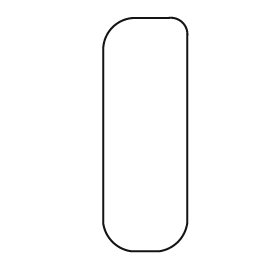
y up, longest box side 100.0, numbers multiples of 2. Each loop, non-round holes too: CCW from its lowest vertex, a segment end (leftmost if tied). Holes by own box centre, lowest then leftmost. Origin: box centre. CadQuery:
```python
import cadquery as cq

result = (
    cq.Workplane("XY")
    .moveTo(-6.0, -50.0)
    .lineTo(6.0, -50.0)
    .threePointArc((14.0, -46.0), (18.0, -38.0))
    .lineTo(18.0, 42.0)
    .threePointArc((16.0, 48.0), (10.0, 50.0))
    .lineTo(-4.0, 50.0)
    .threePointArc((-14.0, 46.0), (-18.0, 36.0))
    .lineTo(-18.0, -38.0)
    .threePointArc((-14.0, -46.0), (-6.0, -50.0))
    .close()
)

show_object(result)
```